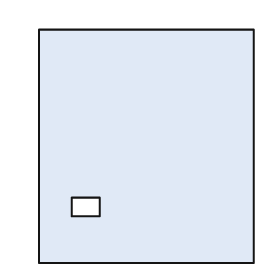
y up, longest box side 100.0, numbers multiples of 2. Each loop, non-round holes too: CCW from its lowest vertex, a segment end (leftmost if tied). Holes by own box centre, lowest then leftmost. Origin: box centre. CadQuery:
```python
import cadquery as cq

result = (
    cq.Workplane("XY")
    .moveTo(-46.0, -50.0)
    .lineTo(46.0, -50.0)
    .lineTo(46.0, 50.0)
    .lineTo(-46.0, 50.0)
    .close()
    .moveTo(-32.0, -30.0)
    .lineTo(-20.0, -30.0)
    .lineTo(-20.0, -22.0)
    .lineTo(-32.0, -22.0)
    .close()
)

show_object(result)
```